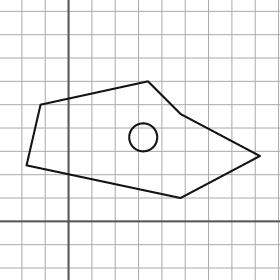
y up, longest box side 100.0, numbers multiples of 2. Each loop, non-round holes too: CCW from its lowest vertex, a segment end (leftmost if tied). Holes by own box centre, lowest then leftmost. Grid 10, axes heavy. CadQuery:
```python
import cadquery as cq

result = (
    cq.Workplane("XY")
    .moveTo(48.0, 10.0)
    .lineTo(82.0, 28.0)
    .lineTo(48.0, 46.0)
    .lineTo(34.0, 60.0)
    .lineTo(-12.0, 50.0)
    .lineTo(-18.0, 24.0)
    .close()
    .moveTo(32.0, 36.0)
    .circle(6.0)
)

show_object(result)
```